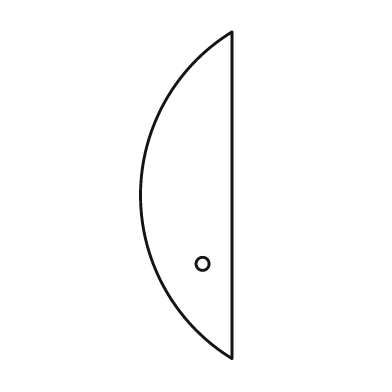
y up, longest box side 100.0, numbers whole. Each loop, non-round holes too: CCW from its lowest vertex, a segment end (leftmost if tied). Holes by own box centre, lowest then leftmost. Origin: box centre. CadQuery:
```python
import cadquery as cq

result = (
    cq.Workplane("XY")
    .moveTo(14.0, -50.0)
    .lineTo(14.0, 50.0)
    .threePointArc((-14.0, 0.0), (14.0, -50.0))
    .close()
    .moveTo(5.0, -21.0)
    .circle(2.0)
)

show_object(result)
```